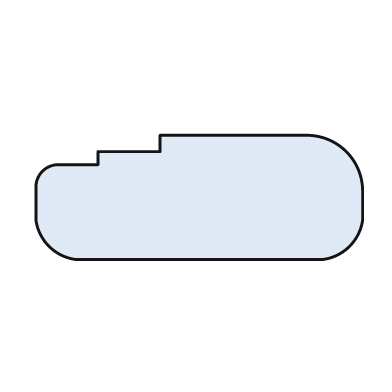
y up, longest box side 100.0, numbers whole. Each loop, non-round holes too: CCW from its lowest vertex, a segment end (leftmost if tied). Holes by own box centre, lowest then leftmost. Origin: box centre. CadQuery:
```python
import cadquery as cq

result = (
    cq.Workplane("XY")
    .moveTo(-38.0, -19.0)
    .lineTo(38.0, -19.0)
    .threePointArc((46.0, -15.0), (50.0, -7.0))
    .lineTo(50.0, 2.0)
    .threePointArc((45.0, 14.0), (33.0, 19.0))
    .lineTo(-12.0, 19.0)
    .lineTo(-12.0, 14.0)
    .lineTo(-31.0, 14.0)
    .lineTo(-31.0, 10.0)
    .lineTo(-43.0, 10.0)
    .threePointArc((-48.0, 8.0), (-50.0, 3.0))
    .lineTo(-50.0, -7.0)
    .threePointArc((-46.0, -15.0), (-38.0, -19.0))
    .close()
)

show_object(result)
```